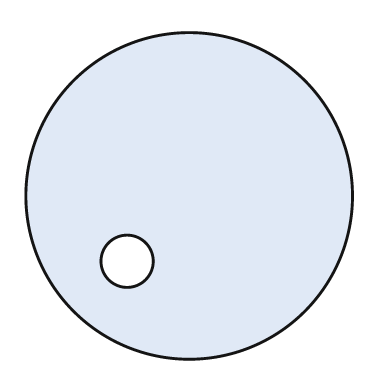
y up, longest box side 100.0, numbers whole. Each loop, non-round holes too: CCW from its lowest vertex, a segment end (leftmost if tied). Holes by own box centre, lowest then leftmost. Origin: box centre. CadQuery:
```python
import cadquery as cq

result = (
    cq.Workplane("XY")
    .moveTo(0.0, 0.0)
    .circle(50.0)
    .moveTo(-19.0, -20.0)
    .circle(8.0)
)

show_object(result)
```